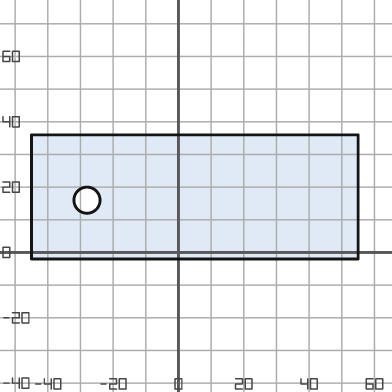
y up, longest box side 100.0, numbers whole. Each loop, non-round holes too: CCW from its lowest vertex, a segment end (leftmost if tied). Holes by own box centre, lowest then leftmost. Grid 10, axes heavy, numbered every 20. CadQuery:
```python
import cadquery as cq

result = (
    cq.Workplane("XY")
    .moveTo(-45.0, -2.0)
    .lineTo(55.0, -2.0)
    .lineTo(55.0, 36.0)
    .lineTo(-45.0, 36.0)
    .close()
    .moveTo(-28.0, 16.0)
    .circle(4.0)
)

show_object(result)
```